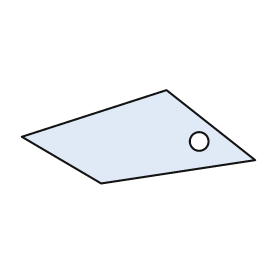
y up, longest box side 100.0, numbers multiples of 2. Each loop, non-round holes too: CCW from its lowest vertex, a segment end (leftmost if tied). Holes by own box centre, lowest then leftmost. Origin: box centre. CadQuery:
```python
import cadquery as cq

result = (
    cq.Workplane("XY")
    .moveTo(-16.0, -20.0)
    .lineTo(50.0, -10.0)
    .lineTo(12.0, 20.0)
    .lineTo(-50.0, 0.0)
    .close()
    .moveTo(26.0, -2.0)
    .circle(4.0)
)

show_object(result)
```